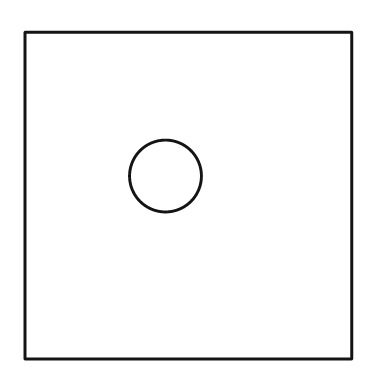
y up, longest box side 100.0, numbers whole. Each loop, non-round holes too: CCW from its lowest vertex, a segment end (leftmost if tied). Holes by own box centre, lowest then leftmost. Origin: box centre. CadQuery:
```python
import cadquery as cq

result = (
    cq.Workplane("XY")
    .moveTo(-50.0, -50.0)
    .lineTo(50.0, -50.0)
    .lineTo(50.0, 50.0)
    .lineTo(-50.0, 50.0)
    .close()
    .moveTo(-7.0, 6.0)
    .circle(11.0)
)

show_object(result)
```